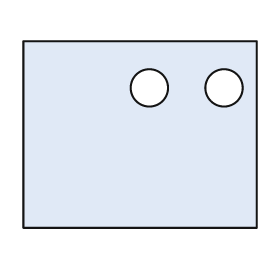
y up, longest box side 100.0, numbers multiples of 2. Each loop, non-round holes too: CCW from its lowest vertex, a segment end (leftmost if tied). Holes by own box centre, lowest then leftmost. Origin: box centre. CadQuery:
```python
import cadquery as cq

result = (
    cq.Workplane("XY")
    .moveTo(-50.0, -40.0)
    .lineTo(50.0, -40.0)
    .lineTo(50.0, 40.0)
    .lineTo(-50.0, 40.0)
    .close()
    .moveTo(4.0, 20.0)
    .circle(8.0)
    .moveTo(36.0, 20.0)
    .circle(8.0)
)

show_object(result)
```